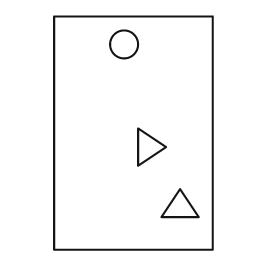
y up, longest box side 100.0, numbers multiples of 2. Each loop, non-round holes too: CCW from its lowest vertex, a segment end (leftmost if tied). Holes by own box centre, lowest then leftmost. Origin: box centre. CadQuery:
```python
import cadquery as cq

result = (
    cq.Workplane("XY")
    .moveTo(-34.0, -50.0)
    .lineTo(34.0, -50.0)
    .lineTo(34.0, 50.0)
    .lineTo(-34.0, 50.0)
    .close()
    .moveTo(12.0, -36.0)
    .lineTo(28.0, -36.0)
    .lineTo(20.0, -24.0)
    .close()
    .moveTo(2.0, -14.0)
    .lineTo(14.0, -6.0)
    .lineTo(2.0, 2.0)
    .close()
    .moveTo(-4.0, 38.0)
    .circle(6.0)
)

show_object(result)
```